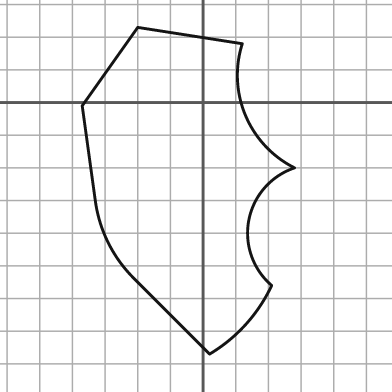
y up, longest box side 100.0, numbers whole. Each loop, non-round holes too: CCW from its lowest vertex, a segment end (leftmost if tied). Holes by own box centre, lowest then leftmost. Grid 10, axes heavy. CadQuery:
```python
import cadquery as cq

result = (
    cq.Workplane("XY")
    .moveTo(2.0, -77.0)
    .threePointArc((13.0, -68.0), (21.0, -56.0))
    .threePointArc((14.0, -36.0), (28.0, -20.0))
    .threePointArc((13.0, -4.0), (12.0, 18.0))
    .lineTo(-20.0, 23.0)
    .lineTo(-37.0, -1.0)
    .lineTo(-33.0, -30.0)
    .threePointArc((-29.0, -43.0), (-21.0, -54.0))
    .close()
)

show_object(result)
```